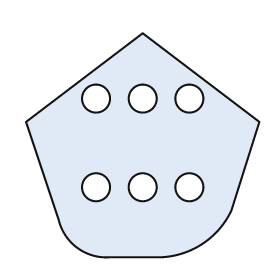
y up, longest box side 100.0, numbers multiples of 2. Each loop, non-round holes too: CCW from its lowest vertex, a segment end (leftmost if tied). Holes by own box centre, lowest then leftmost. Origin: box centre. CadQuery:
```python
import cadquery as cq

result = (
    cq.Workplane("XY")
    .moveTo(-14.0, -48.0)
    .lineTo(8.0, -48.0)
    .threePointArc((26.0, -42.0), (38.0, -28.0))
    .lineTo(50.0, 10.0)
    .lineTo(0.0, 48.0)
    .lineTo(-50.0, 10.0)
    .lineTo(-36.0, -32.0)
    .threePointArc((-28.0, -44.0), (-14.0, -48.0))
    .close()
    .moveTo(-20.0, -18.0)
    .circle(6.0)
    .moveTo(0.0, -18.0)
    .circle(6.0)
    .moveTo(20.0, -18.0)
    .circle(6.0)
    .moveTo(-20.0, 20.0)
    .circle(6.0)
    .moveTo(0.0, 20.0)
    .circle(6.0)
    .moveTo(20.0, 20.0)
    .circle(6.0)
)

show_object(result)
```